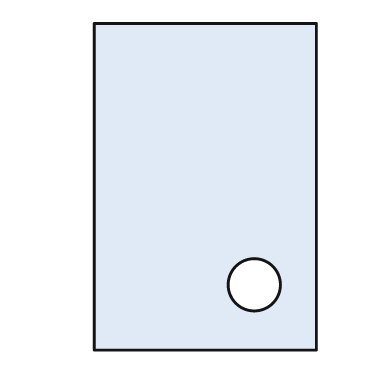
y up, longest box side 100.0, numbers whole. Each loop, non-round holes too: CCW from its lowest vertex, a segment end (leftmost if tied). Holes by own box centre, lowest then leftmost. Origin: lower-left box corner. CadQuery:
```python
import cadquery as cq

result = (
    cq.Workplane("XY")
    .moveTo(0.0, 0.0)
    .lineTo(68.0, 0.0)
    .lineTo(68.0, 100.0)
    .lineTo(0.0, 100.0)
    .close()
    .moveTo(49.0, 20.0)
    .circle(8.0)
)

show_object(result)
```